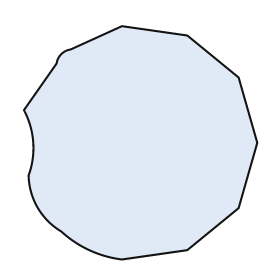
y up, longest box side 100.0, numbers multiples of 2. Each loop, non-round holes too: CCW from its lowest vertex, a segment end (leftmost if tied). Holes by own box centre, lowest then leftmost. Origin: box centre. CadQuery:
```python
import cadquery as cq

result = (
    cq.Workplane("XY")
    .moveTo(-8.0, -50.0)
    .lineTo(20.0, -46.0)
    .lineTo(42.0, -28.0)
    .lineTo(50.0, 0.0)
    .lineTo(42.0, 28.0)
    .lineTo(20.0, 46.0)
    .lineTo(-8.0, 50.0)
    .lineTo(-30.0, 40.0)
    .threePointArc((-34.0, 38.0), (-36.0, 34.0))
    .lineTo(-50.0, 14.0)
    .threePointArc((-46.0, 0.0), (-48.0, -14.0))
    .threePointArc((-44.0, -28.0), (-34.0, -38.0))
    .threePointArc((-22.0, -46.0), (-8.0, -50.0))
    .close()
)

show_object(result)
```